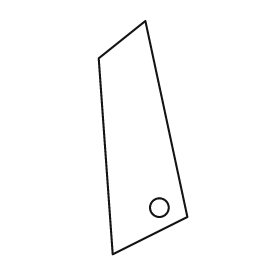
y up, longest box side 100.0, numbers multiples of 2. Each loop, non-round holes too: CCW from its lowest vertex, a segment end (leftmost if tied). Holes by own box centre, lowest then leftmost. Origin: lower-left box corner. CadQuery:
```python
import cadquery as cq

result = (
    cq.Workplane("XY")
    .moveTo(6.0, 0.0)
    .lineTo(38.0, 16.0)
    .lineTo(20.0, 100.0)
    .lineTo(0.0, 84.0)
    .close()
    .moveTo(26.0, 20.0)
    .circle(4.0)
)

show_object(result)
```